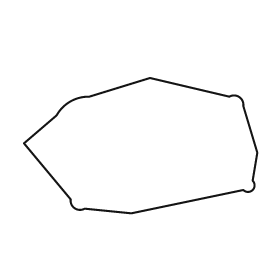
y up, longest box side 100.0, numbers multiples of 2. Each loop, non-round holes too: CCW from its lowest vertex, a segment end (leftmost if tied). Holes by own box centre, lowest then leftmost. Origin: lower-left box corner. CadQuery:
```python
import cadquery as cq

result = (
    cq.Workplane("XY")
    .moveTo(46.0, 0.0)
    .lineTo(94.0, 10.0)
    .threePointArc((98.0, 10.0), (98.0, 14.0))
    .lineTo(100.0, 26.0)
    .lineTo(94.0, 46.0)
    .threePointArc((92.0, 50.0), (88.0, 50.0))
    .lineTo(54.0, 58.0)
    .lineTo(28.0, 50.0)
    .threePointArc((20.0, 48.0), (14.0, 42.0))
    .lineTo(0.0, 30.0)
    .lineTo(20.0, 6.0)
    .threePointArc((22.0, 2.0), (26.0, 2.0))
    .close()
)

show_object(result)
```